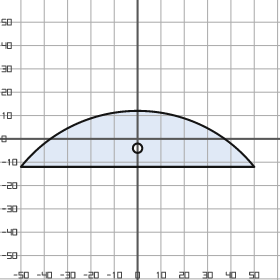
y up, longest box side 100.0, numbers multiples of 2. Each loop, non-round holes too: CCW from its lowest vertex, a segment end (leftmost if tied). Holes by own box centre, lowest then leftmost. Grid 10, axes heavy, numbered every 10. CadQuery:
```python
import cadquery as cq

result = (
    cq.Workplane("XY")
    .moveTo(-50.0, -12.0)
    .lineTo(50.0, -12.0)
    .threePointArc((0.0, 12.0), (-50.0, -12.0))
    .close()
    .moveTo(0.0, -4.0)
    .circle(2.0)
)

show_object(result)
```